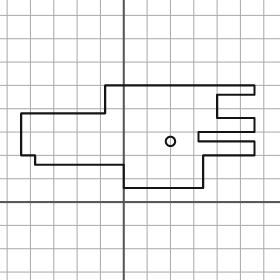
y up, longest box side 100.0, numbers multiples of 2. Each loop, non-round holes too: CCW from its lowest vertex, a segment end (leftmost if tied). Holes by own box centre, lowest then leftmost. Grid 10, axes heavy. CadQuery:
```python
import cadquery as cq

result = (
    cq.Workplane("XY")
    .moveTo(0.0, 6.0)
    .lineTo(34.0, 6.0)
    .lineTo(34.0, 20.0)
    .lineTo(56.0, 20.0)
    .lineTo(56.0, 26.0)
    .lineTo(32.0, 26.0)
    .lineTo(32.0, 30.0)
    .lineTo(56.0, 30.0)
    .lineTo(56.0, 36.0)
    .lineTo(40.0, 36.0)
    .lineTo(40.0, 46.0)
    .lineTo(56.0, 46.0)
    .lineTo(56.0, 50.0)
    .lineTo(-8.0, 50.0)
    .lineTo(-8.0, 38.0)
    .lineTo(-44.0, 38.0)
    .lineTo(-44.0, 20.0)
    .lineTo(-38.0, 20.0)
    .lineTo(-38.0, 16.0)
    .lineTo(0.0, 16.0)
    .close()
    .moveTo(20.0, 26.0)
    .circle(2.0)
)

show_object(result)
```